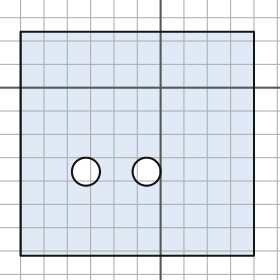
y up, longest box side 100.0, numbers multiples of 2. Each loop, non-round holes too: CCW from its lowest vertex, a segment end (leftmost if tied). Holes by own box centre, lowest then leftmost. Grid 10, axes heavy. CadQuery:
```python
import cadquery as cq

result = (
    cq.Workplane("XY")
    .moveTo(-60.0, -72.0)
    .lineTo(40.0, -72.0)
    .lineTo(40.0, 24.0)
    .lineTo(-60.0, 24.0)
    .close()
    .moveTo(-32.0, -36.0)
    .circle(6.0)
    .moveTo(-6.0, -36.0)
    .circle(6.0)
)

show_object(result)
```